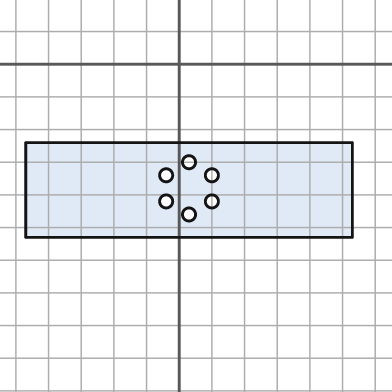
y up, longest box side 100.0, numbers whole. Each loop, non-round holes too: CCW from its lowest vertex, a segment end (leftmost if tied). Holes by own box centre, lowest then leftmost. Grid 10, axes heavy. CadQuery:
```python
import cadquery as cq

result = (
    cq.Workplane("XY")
    .moveTo(-47.0, -53.0)
    .lineTo(53.0, -53.0)
    .lineTo(53.0, -24.0)
    .lineTo(-47.0, -24.0)
    .close()
    .moveTo(3.0, -46.0)
    .circle(2.0)
    .moveTo(-4.0, -42.0)
    .circle(2.0)
    .moveTo(10.0, -42.0)
    .circle(2.0)
    .moveTo(-4.0, -34.0)
    .circle(2.0)
    .moveTo(10.0, -34.0)
    .circle(2.0)
    .moveTo(3.0, -30.0)
    .circle(2.0)
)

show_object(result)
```